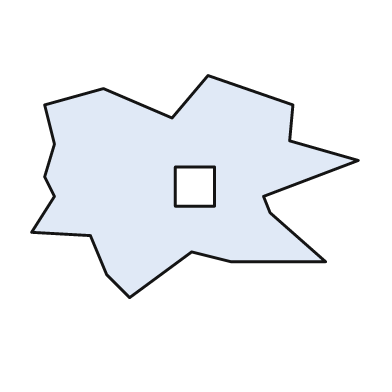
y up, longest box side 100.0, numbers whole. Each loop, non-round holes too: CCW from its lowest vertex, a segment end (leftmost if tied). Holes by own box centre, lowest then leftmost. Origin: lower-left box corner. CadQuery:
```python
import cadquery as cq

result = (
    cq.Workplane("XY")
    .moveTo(30.0, 0.0)
    .lineTo(49.0, 14.0)
    .lineTo(61.0, 11.0)
    .lineTo(90.0, 11.0)
    .lineTo(73.0, 26.0)
    .lineTo(71.0, 31.0)
    .lineTo(100.0, 42.0)
    .lineTo(79.0, 48.0)
    .lineTo(80.0, 59.0)
    .lineTo(54.0, 68.0)
    .lineTo(43.0, 55.0)
    .lineTo(22.0, 64.0)
    .lineTo(4.0, 59.0)
    .lineTo(7.0, 47.0)
    .lineTo(4.0, 37.0)
    .lineTo(7.0, 31.0)
    .lineTo(0.0, 20.0)
    .lineTo(18.0, 19.0)
    .lineTo(23.0, 7.0)
    .close()
    .moveTo(44.0, 28.0)
    .lineTo(56.0, 28.0)
    .lineTo(56.0, 40.0)
    .lineTo(44.0, 40.0)
    .close()
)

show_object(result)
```